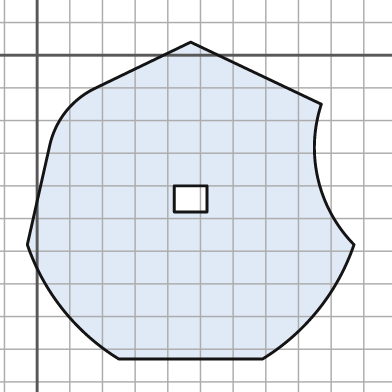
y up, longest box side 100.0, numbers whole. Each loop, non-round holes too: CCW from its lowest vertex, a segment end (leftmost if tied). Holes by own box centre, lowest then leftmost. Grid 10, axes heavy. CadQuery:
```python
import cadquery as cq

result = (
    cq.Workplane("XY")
    .moveTo(25.0, -93.0)
    .lineTo(69.0, -93.0)
    .threePointArc((86.0, -78.0), (97.0, -58.0))
    .threePointArc((86.0, -38.0), (87.0, -15.0))
    .lineTo(47.0, 4.0)
    .lineTo(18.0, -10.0)
    .threePointArc((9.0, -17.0), (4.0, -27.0))
    .lineTo(-3.0, -58.0)
    .threePointArc((8.0, -78.0), (25.0, -93.0))
    .close()
    .moveTo(42.0, -48.0)
    .lineTo(52.0, -48.0)
    .lineTo(52.0, -40.0)
    .lineTo(42.0, -40.0)
    .close()
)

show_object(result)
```